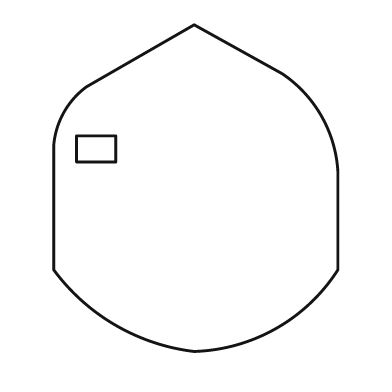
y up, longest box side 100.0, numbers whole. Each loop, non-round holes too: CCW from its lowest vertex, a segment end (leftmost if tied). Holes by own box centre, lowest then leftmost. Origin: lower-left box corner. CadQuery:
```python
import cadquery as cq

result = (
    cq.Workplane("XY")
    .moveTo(43.0, 0.0)
    .threePointArc((68.0, 7.0), (87.0, 25.0))
    .lineTo(87.0, 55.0)
    .threePointArc((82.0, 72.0), (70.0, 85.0))
    .lineTo(43.0, 100.0)
    .lineTo(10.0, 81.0)
    .threePointArc((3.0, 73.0), (0.0, 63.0))
    .lineTo(0.0, 25.0)
    .threePointArc((19.0, 8.0), (43.0, 0.0))
    .close()
    .moveTo(7.0, 58.0)
    .lineTo(19.0, 58.0)
    .lineTo(19.0, 66.0)
    .lineTo(7.0, 66.0)
    .close()
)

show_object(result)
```